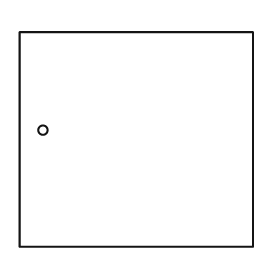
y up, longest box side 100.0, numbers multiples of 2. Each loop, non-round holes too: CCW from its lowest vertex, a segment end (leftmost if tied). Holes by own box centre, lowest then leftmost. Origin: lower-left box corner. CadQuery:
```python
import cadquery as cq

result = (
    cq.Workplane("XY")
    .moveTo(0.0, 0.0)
    .lineTo(100.0, 0.0)
    .lineTo(100.0, 92.0)
    .lineTo(0.0, 92.0)
    .close()
    .moveTo(10.0, 50.0)
    .circle(2.0)
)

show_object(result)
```